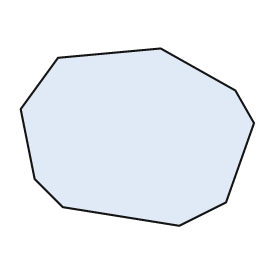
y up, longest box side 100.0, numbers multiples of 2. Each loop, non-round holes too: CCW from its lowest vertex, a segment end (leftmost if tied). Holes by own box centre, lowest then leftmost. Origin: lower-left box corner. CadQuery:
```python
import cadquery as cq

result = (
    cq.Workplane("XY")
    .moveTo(68.0, 0.0)
    .lineTo(88.0, 10.0)
    .lineTo(100.0, 44.0)
    .lineTo(92.0, 58.0)
    .lineTo(60.0, 76.0)
    .lineTo(16.0, 72.0)
    .lineTo(0.0, 50.0)
    .lineTo(6.0, 20.0)
    .lineTo(18.0, 8.0)
    .close()
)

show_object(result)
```